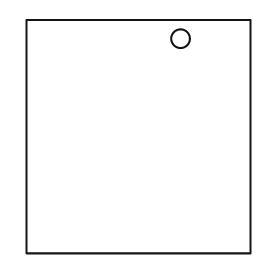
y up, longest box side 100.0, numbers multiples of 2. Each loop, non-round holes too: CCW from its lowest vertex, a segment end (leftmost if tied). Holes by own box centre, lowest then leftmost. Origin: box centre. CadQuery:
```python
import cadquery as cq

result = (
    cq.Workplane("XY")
    .moveTo(-48.0, -50.0)
    .lineTo(48.0, -50.0)
    .lineTo(48.0, 50.0)
    .lineTo(-48.0, 50.0)
    .close()
    .moveTo(18.0, 42.0)
    .circle(4.0)
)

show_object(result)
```